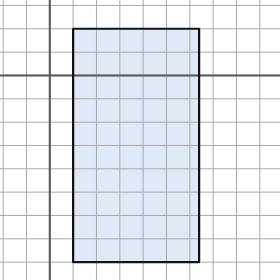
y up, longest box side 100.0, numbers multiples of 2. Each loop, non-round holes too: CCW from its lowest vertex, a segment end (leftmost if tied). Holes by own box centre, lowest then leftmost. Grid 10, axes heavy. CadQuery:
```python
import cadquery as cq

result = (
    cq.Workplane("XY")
    .moveTo(10.0, -80.0)
    .lineTo(64.0, -80.0)
    .lineTo(64.0, 20.0)
    .lineTo(10.0, 20.0)
    .close()
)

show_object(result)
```